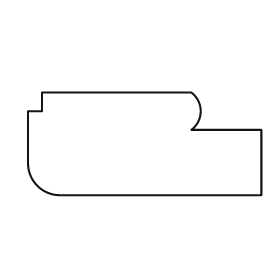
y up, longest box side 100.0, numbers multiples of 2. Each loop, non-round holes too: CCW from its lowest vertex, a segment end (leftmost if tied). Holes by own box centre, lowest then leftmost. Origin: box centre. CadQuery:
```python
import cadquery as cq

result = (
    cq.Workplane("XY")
    .moveTo(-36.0, -22.0)
    .lineTo(50.0, -22.0)
    .lineTo(50.0, 6.0)
    .lineTo(20.0, 6.0)
    .threePointArc((24.0, 14.0), (20.0, 22.0))
    .lineTo(-44.0, 22.0)
    .lineTo(-44.0, 14.0)
    .lineTo(-50.0, 14.0)
    .lineTo(-50.0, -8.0)
    .threePointArc((-46.0, -18.0), (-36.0, -22.0))
    .close()
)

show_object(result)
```